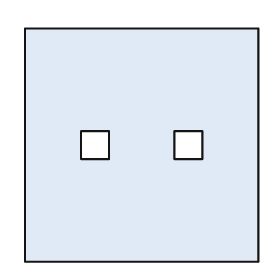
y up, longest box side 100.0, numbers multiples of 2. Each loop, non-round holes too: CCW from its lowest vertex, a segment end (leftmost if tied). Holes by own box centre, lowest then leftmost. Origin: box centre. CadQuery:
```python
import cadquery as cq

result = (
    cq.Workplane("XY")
    .moveTo(-50.0, -50.0)
    .lineTo(50.0, -50.0)
    .lineTo(50.0, 50.0)
    .lineTo(-50.0, 50.0)
    .close()
    .moveTo(-26.0, -6.0)
    .lineTo(-14.0, -6.0)
    .lineTo(-14.0, 6.0)
    .lineTo(-26.0, 6.0)
    .close()
    .moveTo(14.0, -6.0)
    .lineTo(26.0, -6.0)
    .lineTo(26.0, 6.0)
    .lineTo(14.0, 6.0)
    .close()
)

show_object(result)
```